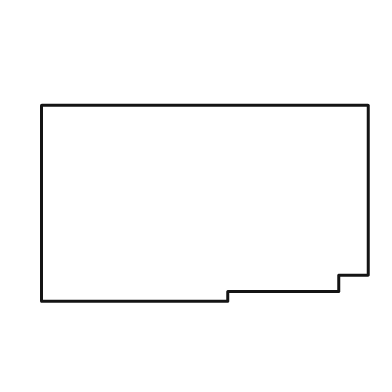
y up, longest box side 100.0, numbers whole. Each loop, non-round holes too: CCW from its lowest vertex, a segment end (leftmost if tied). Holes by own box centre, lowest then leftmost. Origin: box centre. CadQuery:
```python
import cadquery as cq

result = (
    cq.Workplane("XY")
    .moveTo(-50.0, -30.0)
    .lineTo(7.0, -30.0)
    .lineTo(7.0, -27.0)
    .lineTo(41.0, -27.0)
    .lineTo(41.0, -22.0)
    .lineTo(50.0, -22.0)
    .lineTo(50.0, 30.0)
    .lineTo(-50.0, 30.0)
    .close()
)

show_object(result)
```